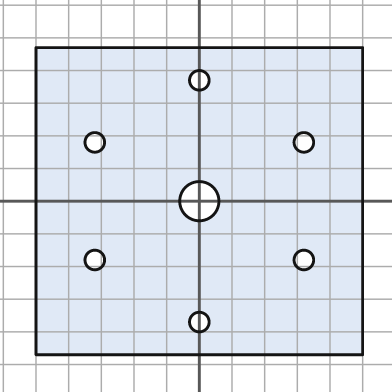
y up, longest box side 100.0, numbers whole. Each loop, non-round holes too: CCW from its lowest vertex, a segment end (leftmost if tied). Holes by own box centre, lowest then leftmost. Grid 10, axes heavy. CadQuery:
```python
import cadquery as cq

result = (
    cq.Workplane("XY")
    .moveTo(-50.0, -47.0)
    .lineTo(50.0, -47.0)
    .lineTo(50.0, 47.0)
    .lineTo(-50.0, 47.0)
    .close()
    .moveTo(0.0, -37.0)
    .circle(3.0)
    .moveTo(-32.0, -18.0)
    .circle(3.0)
    .moveTo(32.0, -18.0)
    .circle(3.0)
    .moveTo(0.0, 0.0)
    .circle(6.0)
    .moveTo(-32.0, 18.0)
    .circle(3.0)
    .moveTo(32.0, 18.0)
    .circle(3.0)
    .moveTo(0.0, 37.0)
    .circle(3.0)
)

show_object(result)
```